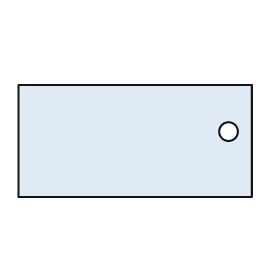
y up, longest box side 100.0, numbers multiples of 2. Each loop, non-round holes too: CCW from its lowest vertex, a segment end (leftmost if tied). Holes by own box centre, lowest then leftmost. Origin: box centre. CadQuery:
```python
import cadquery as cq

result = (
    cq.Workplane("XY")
    .moveTo(-50.0, -24.0)
    .lineTo(50.0, -24.0)
    .lineTo(50.0, 24.0)
    .lineTo(-50.0, 24.0)
    .close()
    .moveTo(40.0, 4.0)
    .circle(4.0)
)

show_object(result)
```